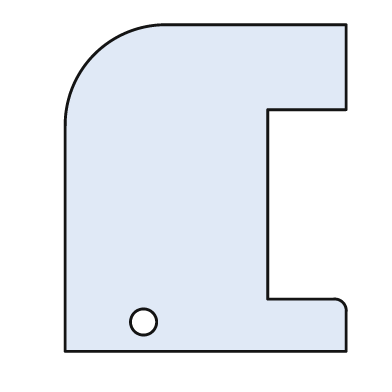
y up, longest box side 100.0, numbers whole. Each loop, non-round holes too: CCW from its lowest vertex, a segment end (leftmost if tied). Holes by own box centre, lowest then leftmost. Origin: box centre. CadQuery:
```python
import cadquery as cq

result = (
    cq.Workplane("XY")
    .moveTo(-43.0, -50.0)
    .lineTo(43.0, -50.0)
    .lineTo(43.0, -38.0)
    .threePointArc((42.0, -35.0), (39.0, -34.0))
    .lineTo(19.0, -34.0)
    .lineTo(19.0, 24.0)
    .lineTo(43.0, 24.0)
    .lineTo(43.0, 50.0)
    .lineTo(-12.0, 50.0)
    .threePointArc((-34.0, 41.0), (-43.0, 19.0))
    .close()
    .moveTo(-19.0, -41.0)
    .circle(4.0)
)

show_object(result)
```